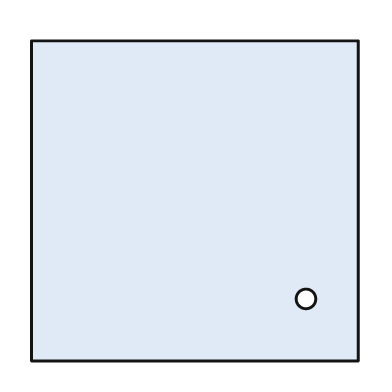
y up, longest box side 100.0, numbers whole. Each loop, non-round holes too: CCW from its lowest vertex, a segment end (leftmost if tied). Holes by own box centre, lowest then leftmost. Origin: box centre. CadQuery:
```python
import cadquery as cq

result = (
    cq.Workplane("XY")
    .moveTo(-50.0, -49.0)
    .lineTo(50.0, -49.0)
    .lineTo(50.0, 49.0)
    .lineTo(-50.0, 49.0)
    .close()
    .moveTo(34.0, -30.0)
    .circle(3.0)
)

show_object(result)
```